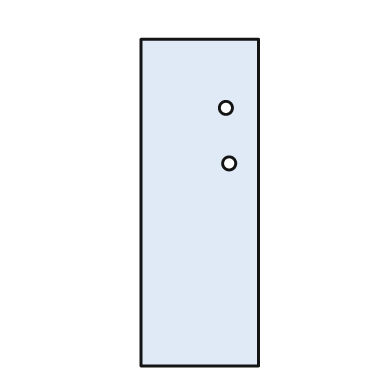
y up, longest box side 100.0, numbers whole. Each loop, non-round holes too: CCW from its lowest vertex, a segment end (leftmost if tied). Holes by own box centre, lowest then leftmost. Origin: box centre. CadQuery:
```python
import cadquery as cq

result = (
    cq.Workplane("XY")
    .moveTo(-18.0, -50.0)
    .lineTo(18.0, -50.0)
    .lineTo(18.0, 50.0)
    .lineTo(-18.0, 50.0)
    .close()
    .moveTo(9.0, 12.0)
    .circle(2.0)
    .moveTo(8.0, 29.0)
    .circle(2.0)
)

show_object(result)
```